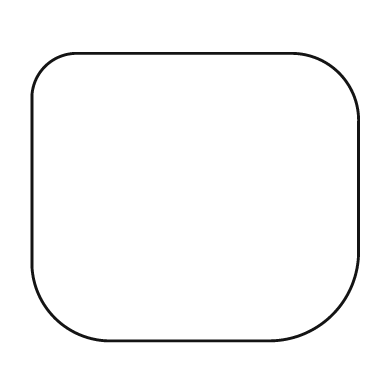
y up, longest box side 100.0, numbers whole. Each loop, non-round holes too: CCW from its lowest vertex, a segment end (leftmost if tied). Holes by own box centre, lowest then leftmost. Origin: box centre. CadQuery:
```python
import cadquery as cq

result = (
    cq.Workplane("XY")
    .moveTo(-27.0, -44.0)
    .lineTo(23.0, -44.0)
    .threePointArc((42.0, -36.0), (50.0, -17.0))
    .lineTo(50.0, 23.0)
    .threePointArc((44.0, 38.0), (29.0, 44.0))
    .lineTo(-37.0, 44.0)
    .threePointArc((-46.0, 40.0), (-50.0, 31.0))
    .lineTo(-50.0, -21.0)
    .threePointArc((-43.0, -37.0), (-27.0, -44.0))
    .close()
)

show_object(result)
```